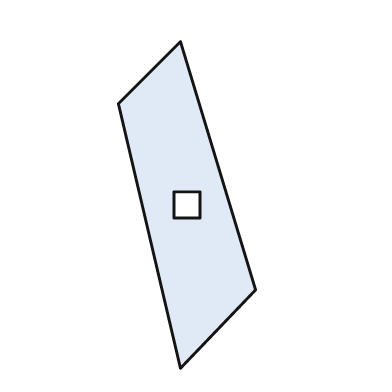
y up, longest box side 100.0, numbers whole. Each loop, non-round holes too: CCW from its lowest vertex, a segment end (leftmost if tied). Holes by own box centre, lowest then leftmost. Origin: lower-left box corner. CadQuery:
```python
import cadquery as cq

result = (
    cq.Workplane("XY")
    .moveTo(19.0, 0.0)
    .lineTo(42.0, 24.0)
    .lineTo(19.0, 100.0)
    .lineTo(0.0, 81.0)
    .close()
    .moveTo(17.0, 46.0)
    .lineTo(25.0, 46.0)
    .lineTo(25.0, 54.0)
    .lineTo(17.0, 54.0)
    .close()
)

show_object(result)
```